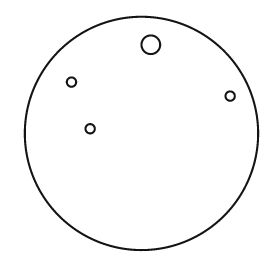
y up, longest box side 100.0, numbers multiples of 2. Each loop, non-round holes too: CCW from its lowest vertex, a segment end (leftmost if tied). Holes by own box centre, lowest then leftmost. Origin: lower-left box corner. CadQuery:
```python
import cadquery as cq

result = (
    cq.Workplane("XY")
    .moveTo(50.0, 50.0)
    .circle(50.0)
    .moveTo(28.0, 52.0)
    .circle(2.0)
    .moveTo(88.0, 66.0)
    .circle(2.0)
    .moveTo(20.0, 72.0)
    .circle(2.0)
    .moveTo(54.0, 88.0)
    .circle(4.0)
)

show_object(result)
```